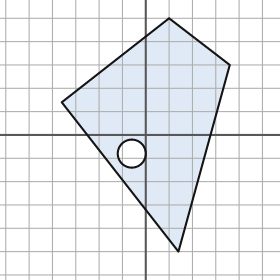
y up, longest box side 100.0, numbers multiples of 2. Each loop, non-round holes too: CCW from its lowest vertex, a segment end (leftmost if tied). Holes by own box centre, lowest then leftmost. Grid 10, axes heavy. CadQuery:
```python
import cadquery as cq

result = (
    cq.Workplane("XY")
    .moveTo(14.0, -50.0)
    .lineTo(36.0, 30.0)
    .lineTo(10.0, 50.0)
    .lineTo(-36.0, 14.0)
    .close()
    .moveTo(-6.0, -8.0)
    .circle(6.0)
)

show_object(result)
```